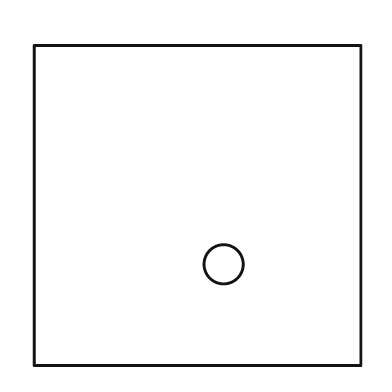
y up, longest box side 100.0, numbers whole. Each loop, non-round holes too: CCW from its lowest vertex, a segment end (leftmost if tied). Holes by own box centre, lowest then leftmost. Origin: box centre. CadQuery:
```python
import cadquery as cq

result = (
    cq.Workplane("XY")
    .moveTo(-50.0, -49.0)
    .lineTo(50.0, -49.0)
    .lineTo(50.0, 49.0)
    .lineTo(-50.0, 49.0)
    .close()
    .moveTo(8.0, -18.0)
    .circle(6.0)
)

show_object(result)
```